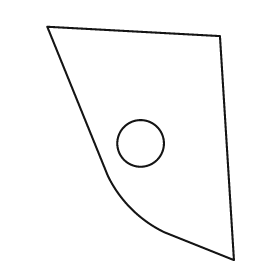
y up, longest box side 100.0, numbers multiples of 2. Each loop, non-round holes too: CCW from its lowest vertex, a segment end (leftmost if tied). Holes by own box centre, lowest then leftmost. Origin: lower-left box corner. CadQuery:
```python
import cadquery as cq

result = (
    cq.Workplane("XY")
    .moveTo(80.0, 0.0)
    .lineTo(74.0, 96.0)
    .lineTo(0.0, 100.0)
    .lineTo(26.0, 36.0)
    .threePointArc((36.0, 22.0), (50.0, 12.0))
    .close()
    .moveTo(40.0, 50.0)
    .circle(10.0)
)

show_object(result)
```